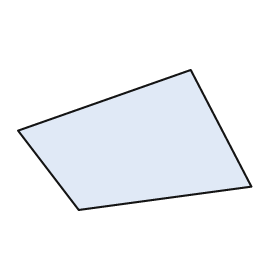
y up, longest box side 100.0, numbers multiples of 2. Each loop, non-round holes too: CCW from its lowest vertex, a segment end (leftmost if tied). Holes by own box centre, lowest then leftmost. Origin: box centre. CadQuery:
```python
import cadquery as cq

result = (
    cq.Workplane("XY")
    .moveTo(-24.0, -30.0)
    .lineTo(50.0, -20.0)
    .lineTo(24.0, 30.0)
    .lineTo(-50.0, 4.0)
    .close()
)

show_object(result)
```